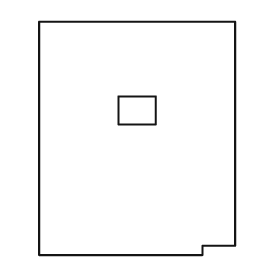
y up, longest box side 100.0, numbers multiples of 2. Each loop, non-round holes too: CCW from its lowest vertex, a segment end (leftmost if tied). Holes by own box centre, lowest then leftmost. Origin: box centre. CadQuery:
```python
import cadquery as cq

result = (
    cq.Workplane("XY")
    .moveTo(-42.0, -50.0)
    .lineTo(28.0, -50.0)
    .lineTo(28.0, -46.0)
    .lineTo(42.0, -46.0)
    .lineTo(42.0, 50.0)
    .lineTo(-42.0, 50.0)
    .close()
    .moveTo(-8.0, 6.0)
    .lineTo(8.0, 6.0)
    .lineTo(8.0, 18.0)
    .lineTo(-8.0, 18.0)
    .close()
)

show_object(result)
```